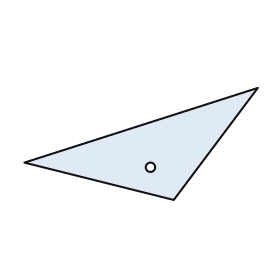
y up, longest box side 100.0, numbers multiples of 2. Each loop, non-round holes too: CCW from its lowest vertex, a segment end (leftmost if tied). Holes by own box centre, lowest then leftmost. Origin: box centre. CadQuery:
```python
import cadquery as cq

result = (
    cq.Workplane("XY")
    .moveTo(14.0, -24.0)
    .lineTo(50.0, 24.0)
    .lineTo(-50.0, -8.0)
    .close()
    .moveTo(4.0, -10.0)
    .circle(2.0)
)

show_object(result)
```